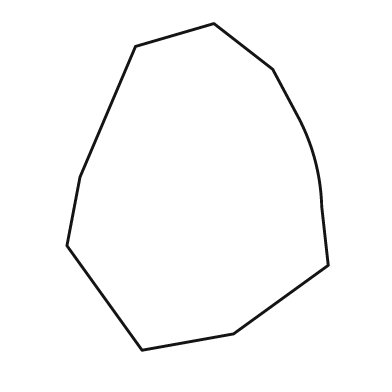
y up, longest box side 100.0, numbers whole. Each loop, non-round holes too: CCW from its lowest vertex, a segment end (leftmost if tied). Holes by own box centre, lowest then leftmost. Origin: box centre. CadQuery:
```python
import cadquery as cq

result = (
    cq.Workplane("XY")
    .moveTo(-17.0, -50.0)
    .lineTo(11.0, -45.0)
    .lineTo(40.0, -24.0)
    .lineTo(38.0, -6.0)
    .threePointArc((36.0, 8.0), (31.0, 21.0))
    .lineTo(23.0, 36.0)
    .lineTo(5.0, 50.0)
    .lineTo(-19.0, 43.0)
    .lineTo(-36.0, 3.0)
    .lineTo(-40.0, -18.0)
    .close()
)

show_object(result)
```